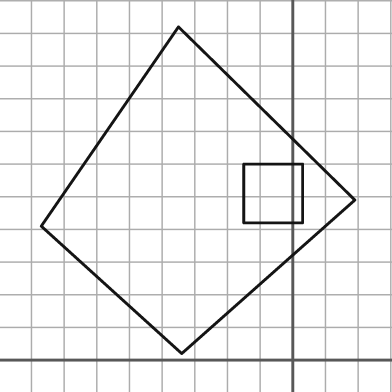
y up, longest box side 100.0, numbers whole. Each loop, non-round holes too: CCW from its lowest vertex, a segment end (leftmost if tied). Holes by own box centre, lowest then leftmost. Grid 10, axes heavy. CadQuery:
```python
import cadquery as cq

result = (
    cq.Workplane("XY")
    .moveTo(-34.0, 2.0)
    .lineTo(19.0, 49.0)
    .lineTo(-35.0, 102.0)
    .lineTo(-77.0, 41.0)
    .close()
    .moveTo(-15.0, 42.0)
    .lineTo(3.0, 42.0)
    .lineTo(3.0, 60.0)
    .lineTo(-15.0, 60.0)
    .close()
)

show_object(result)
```